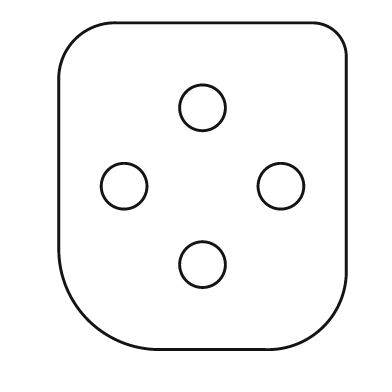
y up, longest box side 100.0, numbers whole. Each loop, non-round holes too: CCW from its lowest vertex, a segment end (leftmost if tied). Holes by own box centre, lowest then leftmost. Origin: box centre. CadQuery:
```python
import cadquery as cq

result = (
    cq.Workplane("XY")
    .moveTo(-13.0, -50.0)
    .lineTo(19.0, -50.0)
    .threePointArc((37.0, -43.0), (44.0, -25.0))
    .lineTo(44.0, 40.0)
    .threePointArc((41.0, 47.0), (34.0, 50.0))
    .lineTo(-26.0, 50.0)
    .threePointArc((-39.0, 45.0), (-44.0, 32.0))
    .lineTo(-44.0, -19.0)
    .threePointArc((-35.0, -41.0), (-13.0, -50.0))
    .close()
    .moveTo(0.0, -24.0)
    .circle(7.0)
    .moveTo(-24.0, 0.0)
    .circle(7.0)
    .moveTo(24.0, 0.0)
    .circle(7.0)
    .moveTo(0.0, 24.0)
    .circle(7.0)
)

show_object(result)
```